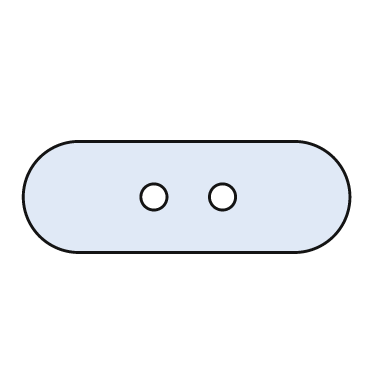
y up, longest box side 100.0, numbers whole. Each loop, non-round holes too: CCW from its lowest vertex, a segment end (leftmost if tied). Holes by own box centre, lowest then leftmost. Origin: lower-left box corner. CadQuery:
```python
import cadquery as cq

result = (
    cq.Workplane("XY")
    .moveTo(17.0, 0.0)
    .lineTo(83.0, 0.0)
    .threePointArc((100.0, 17.0), (83.0, 34.0))
    .lineTo(17.0, 34.0)
    .threePointArc((0.0, 17.0), (17.0, 0.0))
    .close()
    .moveTo(40.0, 17.0)
    .circle(4.0)
    .moveTo(61.0, 17.0)
    .circle(4.0)
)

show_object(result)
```